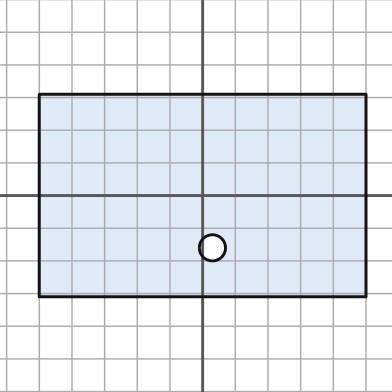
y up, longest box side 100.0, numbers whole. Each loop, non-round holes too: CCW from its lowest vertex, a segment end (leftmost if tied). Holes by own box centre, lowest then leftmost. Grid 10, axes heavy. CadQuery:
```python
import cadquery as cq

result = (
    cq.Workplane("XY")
    .moveTo(-50.0, -31.0)
    .lineTo(50.0, -31.0)
    .lineTo(50.0, 31.0)
    .lineTo(-50.0, 31.0)
    .close()
    .moveTo(3.0, -16.0)
    .circle(4.0)
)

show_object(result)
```